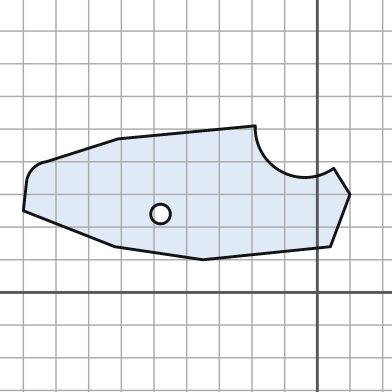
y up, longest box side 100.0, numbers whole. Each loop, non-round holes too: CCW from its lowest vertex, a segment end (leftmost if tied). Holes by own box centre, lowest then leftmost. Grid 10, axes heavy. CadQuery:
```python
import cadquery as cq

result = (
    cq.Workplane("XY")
    .moveTo(-35.0, 10.0)
    .lineTo(4.0, 14.0)
    .lineTo(10.0, 30.0)
    .lineTo(5.0, 38.0)
    .threePointArc((-11.0, 37.0), (-19.0, 51.0))
    .lineTo(-61.0, 47.0)
    .lineTo(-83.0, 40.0)
    .threePointArc((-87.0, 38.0), (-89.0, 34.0))
    .lineTo(-90.0, 25.0)
    .lineTo(-62.0, 14.0)
    .close()
    .moveTo(-48.0, 24.0)
    .circle(3.0)
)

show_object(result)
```